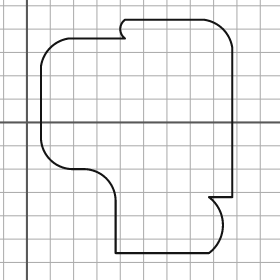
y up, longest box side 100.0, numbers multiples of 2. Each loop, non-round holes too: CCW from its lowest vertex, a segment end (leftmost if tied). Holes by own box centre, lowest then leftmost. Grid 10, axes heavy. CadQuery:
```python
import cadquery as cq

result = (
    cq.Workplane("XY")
    .moveTo(38.0, -56.0)
    .lineTo(78.0, -56.0)
    .threePointArc((84.0, -44.0), (78.0, -32.0))
    .lineTo(88.0, -32.0)
    .lineTo(88.0, 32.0)
    .threePointArc((84.0, 40.0), (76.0, 44.0))
    .lineTo(42.0, 44.0)
    .threePointArc((40.0, 40.0), (42.0, 36.0))
    .lineTo(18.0, 36.0)
    .threePointArc((10.0, 32.0), (6.0, 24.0))
    .lineTo(6.0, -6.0)
    .threePointArc((10.0, -16.0), (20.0, -20.0))
    .lineTo(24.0, -20.0)
    .threePointArc((34.0, -24.0), (38.0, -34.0))
    .close()
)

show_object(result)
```